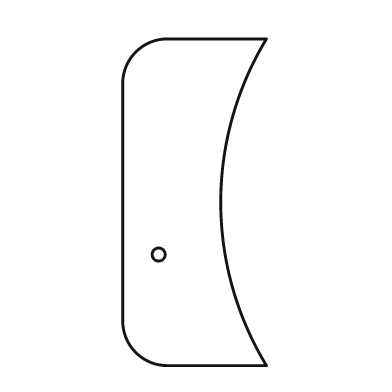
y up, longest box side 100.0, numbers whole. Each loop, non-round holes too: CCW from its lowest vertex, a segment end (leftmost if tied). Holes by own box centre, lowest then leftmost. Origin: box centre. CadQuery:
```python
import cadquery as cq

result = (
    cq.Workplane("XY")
    .moveTo(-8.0, -50.0)
    .lineTo(22.0, -50.0)
    .threePointArc((8.0, 0.0), (22.0, 50.0))
    .lineTo(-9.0, 50.0)
    .threePointArc((-18.0, 46.0), (-22.0, 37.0))
    .lineTo(-22.0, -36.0)
    .threePointArc((-18.0, -46.0), (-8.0, -50.0))
    .close()
    .moveTo(-11.0, -16.0)
    .circle(2.0)
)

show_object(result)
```